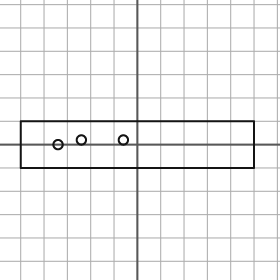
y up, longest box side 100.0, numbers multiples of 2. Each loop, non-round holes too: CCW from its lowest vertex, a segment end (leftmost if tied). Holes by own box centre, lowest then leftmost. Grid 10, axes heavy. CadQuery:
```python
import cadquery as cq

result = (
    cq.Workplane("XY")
    .moveTo(-50.0, -10.0)
    .lineTo(50.0, -10.0)
    .lineTo(50.0, 10.0)
    .lineTo(-50.0, 10.0)
    .close()
    .moveTo(-34.0, 0.0)
    .circle(2.0)
    .moveTo(-24.0, 2.0)
    .circle(2.0)
    .moveTo(-6.0, 2.0)
    .circle(2.0)
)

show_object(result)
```